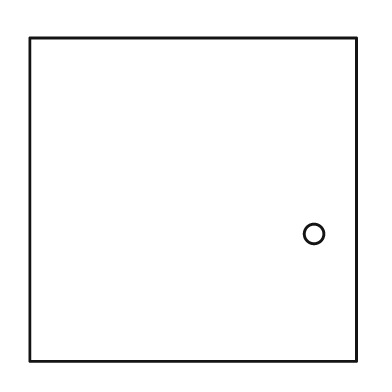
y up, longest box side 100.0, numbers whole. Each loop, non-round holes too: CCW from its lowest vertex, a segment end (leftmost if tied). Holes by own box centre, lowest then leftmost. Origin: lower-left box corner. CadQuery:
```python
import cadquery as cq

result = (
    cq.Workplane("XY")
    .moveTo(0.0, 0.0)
    .lineTo(100.0, 0.0)
    .lineTo(100.0, 99.0)
    .lineTo(0.0, 99.0)
    .close()
    .moveTo(87.0, 39.0)
    .circle(3.0)
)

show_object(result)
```